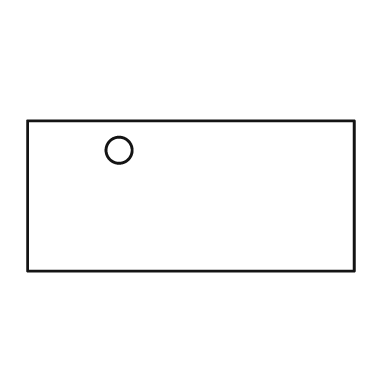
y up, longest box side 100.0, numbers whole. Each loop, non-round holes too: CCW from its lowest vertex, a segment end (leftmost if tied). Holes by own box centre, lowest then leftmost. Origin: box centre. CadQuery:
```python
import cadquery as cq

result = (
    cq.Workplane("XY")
    .moveTo(-50.0, -23.0)
    .lineTo(50.0, -23.0)
    .lineTo(50.0, 23.0)
    .lineTo(-50.0, 23.0)
    .close()
    .moveTo(-22.0, 14.0)
    .circle(4.0)
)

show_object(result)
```